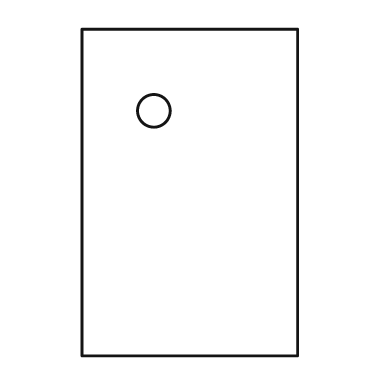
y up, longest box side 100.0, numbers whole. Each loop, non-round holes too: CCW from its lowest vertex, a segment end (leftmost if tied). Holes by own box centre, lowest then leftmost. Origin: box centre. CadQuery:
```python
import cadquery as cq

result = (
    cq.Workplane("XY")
    .moveTo(-33.0, -50.0)
    .lineTo(33.0, -50.0)
    .lineTo(33.0, 50.0)
    .lineTo(-33.0, 50.0)
    .close()
    .moveTo(-11.0, 25.0)
    .circle(5.0)
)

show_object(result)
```